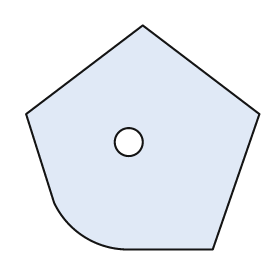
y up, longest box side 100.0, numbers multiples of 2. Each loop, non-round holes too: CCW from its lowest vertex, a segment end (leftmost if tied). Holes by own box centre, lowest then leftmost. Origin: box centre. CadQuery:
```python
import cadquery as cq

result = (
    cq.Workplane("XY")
    .moveTo(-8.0, -48.0)
    .lineTo(30.0, -48.0)
    .lineTo(50.0, 10.0)
    .lineTo(0.0, 48.0)
    .lineTo(-50.0, 10.0)
    .lineTo(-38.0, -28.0)
    .threePointArc((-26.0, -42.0), (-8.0, -48.0))
    .close()
    .moveTo(-6.0, -2.0)
    .circle(6.0)
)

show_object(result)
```